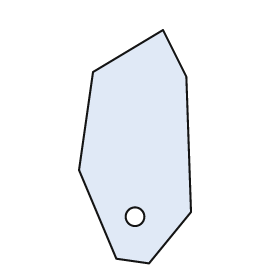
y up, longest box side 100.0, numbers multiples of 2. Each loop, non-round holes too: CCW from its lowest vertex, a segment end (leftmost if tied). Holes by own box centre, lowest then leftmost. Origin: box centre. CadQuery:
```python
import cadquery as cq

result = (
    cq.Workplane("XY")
    .moveTo(6.0, -50.0)
    .lineTo(24.0, -28.0)
    .lineTo(22.0, 30.0)
    .lineTo(12.0, 50.0)
    .lineTo(-18.0, 32.0)
    .lineTo(-24.0, -10.0)
    .lineTo(-8.0, -48.0)
    .close()
    .moveTo(0.0, -30.0)
    .circle(4.0)
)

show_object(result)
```